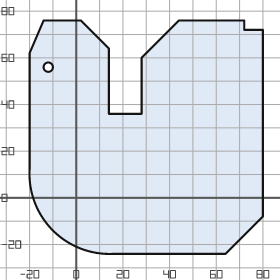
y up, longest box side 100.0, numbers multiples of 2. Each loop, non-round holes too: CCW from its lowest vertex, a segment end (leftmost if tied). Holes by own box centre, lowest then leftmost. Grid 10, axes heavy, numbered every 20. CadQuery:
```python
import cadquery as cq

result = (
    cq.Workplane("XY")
    .moveTo(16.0, -24.0)
    .lineTo(64.0, -24.0)
    .lineTo(80.0, -8.0)
    .lineTo(80.0, 72.0)
    .lineTo(72.0, 72.0)
    .lineTo(72.0, 76.0)
    .lineTo(44.0, 76.0)
    .lineTo(28.0, 60.0)
    .lineTo(28.0, 36.0)
    .lineTo(14.0, 36.0)
    .lineTo(14.0, 64.0)
    .lineTo(2.0, 76.0)
    .lineTo(-14.0, 76.0)
    .lineTo(-20.0, 62.0)
    .lineTo(-20.0, 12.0)
    .threePointArc((-10.0, -14.0), (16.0, -24.0))
    .close()
    .moveTo(-12.0, 56.0)
    .circle(2.0)
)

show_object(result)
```